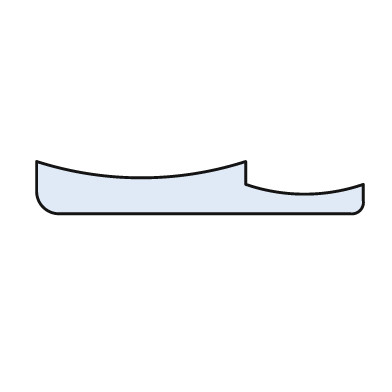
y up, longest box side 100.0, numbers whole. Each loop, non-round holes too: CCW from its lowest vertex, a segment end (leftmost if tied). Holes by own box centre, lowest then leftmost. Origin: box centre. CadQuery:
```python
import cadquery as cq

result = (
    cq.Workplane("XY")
    .moveTo(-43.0, -8.0)
    .lineTo(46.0, -8.0)
    .threePointArc((49.0, -7.0), (50.0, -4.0))
    .lineTo(50.0, 1.0)
    .threePointArc((32.0, -2.0), (14.0, 1.0))
    .lineTo(14.0, 8.0)
    .threePointArc((-18.0, 3.0), (-50.0, 8.0))
    .lineTo(-50.0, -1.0)
    .threePointArc((-48.0, -6.0), (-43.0, -8.0))
    .close()
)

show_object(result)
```